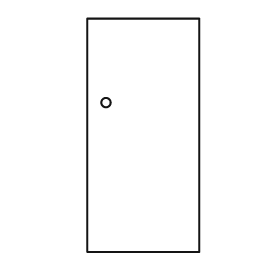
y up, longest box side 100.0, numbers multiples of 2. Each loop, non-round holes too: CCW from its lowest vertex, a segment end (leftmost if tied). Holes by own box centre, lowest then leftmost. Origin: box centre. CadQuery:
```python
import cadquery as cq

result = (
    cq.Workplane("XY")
    .moveTo(-24.0, -50.0)
    .lineTo(24.0, -50.0)
    .lineTo(24.0, 50.0)
    .lineTo(-24.0, 50.0)
    .close()
    .moveTo(-16.0, 14.0)
    .circle(2.0)
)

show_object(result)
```